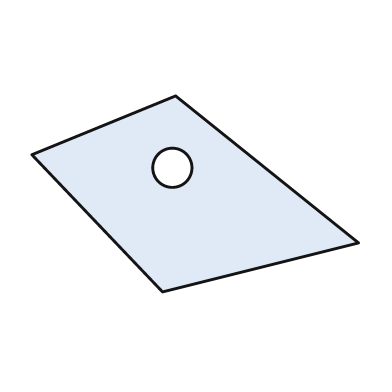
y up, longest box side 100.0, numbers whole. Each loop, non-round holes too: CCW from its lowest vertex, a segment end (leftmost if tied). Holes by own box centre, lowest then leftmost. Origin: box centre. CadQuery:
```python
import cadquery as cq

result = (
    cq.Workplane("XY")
    .moveTo(-10.0, -30.0)
    .lineTo(50.0, -15.0)
    .lineTo(-6.0, 30.0)
    .lineTo(-50.0, 12.0)
    .close()
    .moveTo(-7.0, 8.0)
    .circle(6.0)
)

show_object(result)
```